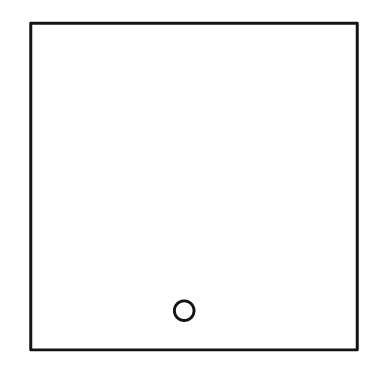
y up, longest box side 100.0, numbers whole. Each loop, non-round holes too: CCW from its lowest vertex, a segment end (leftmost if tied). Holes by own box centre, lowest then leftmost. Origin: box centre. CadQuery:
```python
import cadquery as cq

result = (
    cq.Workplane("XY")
    .moveTo(-50.0, -50.0)
    .lineTo(50.0, -50.0)
    .lineTo(50.0, 50.0)
    .lineTo(-50.0, 50.0)
    .close()
    .moveTo(-3.0, -38.0)
    .circle(3.0)
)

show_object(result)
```